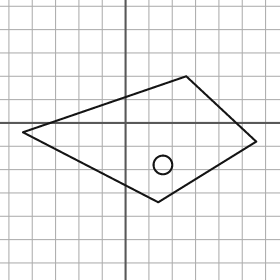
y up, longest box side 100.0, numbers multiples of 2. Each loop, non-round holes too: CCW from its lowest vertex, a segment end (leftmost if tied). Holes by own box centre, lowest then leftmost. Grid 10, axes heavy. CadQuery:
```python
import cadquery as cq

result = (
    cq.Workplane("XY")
    .moveTo(14.0, -34.0)
    .lineTo(56.0, -8.0)
    .lineTo(26.0, 20.0)
    .lineTo(-44.0, -4.0)
    .close()
    .moveTo(16.0, -18.0)
    .circle(4.0)
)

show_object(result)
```